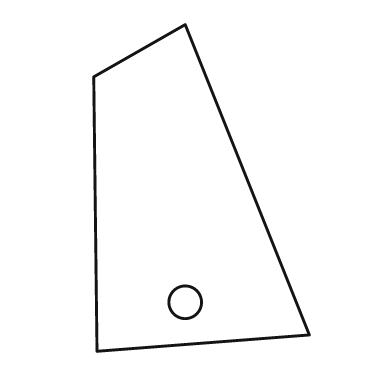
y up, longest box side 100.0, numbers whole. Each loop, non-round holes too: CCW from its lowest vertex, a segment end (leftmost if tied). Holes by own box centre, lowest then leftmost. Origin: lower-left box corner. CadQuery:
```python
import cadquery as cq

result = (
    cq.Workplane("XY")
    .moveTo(1.0, 0.0)
    .lineTo(66.0, 5.0)
    .lineTo(28.0, 100.0)
    .lineTo(0.0, 84.0)
    .close()
    .moveTo(28.0, 15.0)
    .circle(5.0)
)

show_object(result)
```